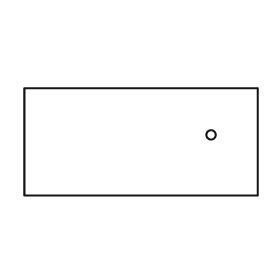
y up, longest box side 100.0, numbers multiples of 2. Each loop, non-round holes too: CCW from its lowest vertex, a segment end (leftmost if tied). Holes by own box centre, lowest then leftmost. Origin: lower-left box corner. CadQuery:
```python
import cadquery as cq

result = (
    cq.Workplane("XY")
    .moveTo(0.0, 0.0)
    .lineTo(100.0, 0.0)
    .lineTo(100.0, 46.0)
    .lineTo(0.0, 46.0)
    .close()
    .moveTo(80.0, 26.0)
    .circle(2.0)
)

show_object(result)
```